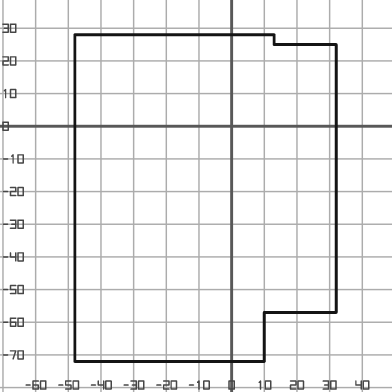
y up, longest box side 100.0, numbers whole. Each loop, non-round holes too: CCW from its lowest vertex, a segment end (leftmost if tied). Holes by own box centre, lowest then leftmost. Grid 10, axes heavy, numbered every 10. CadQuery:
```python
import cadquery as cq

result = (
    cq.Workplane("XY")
    .moveTo(-48.0, -72.0)
    .lineTo(10.0, -72.0)
    .lineTo(10.0, -57.0)
    .lineTo(32.0, -57.0)
    .lineTo(32.0, 25.0)
    .lineTo(13.0, 25.0)
    .lineTo(13.0, 28.0)
    .lineTo(-48.0, 28.0)
    .close()
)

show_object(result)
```